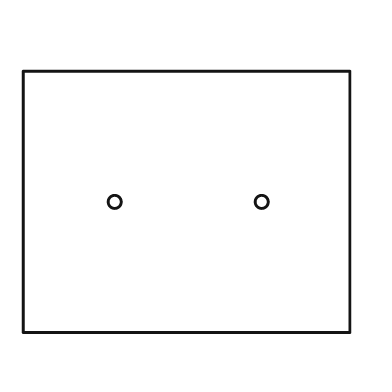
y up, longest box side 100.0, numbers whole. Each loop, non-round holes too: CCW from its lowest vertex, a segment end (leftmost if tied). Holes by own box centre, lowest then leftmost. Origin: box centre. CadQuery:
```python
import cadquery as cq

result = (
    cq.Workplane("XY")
    .moveTo(-50.0, -40.0)
    .lineTo(50.0, -40.0)
    .lineTo(50.0, 40.0)
    .lineTo(-50.0, 40.0)
    .close()
    .moveTo(-22.0, 0.0)
    .circle(2.0)
    .moveTo(23.0, 0.0)
    .circle(2.0)
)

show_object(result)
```